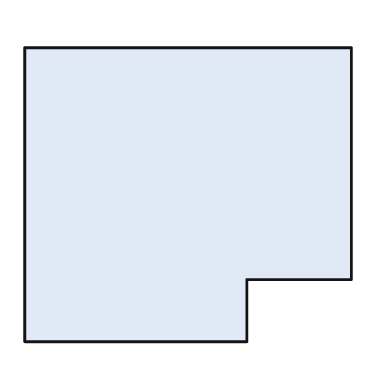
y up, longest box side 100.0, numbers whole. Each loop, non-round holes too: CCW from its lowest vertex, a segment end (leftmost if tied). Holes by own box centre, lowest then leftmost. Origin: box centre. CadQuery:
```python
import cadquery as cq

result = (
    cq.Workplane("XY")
    .moveTo(-50.0, -45.0)
    .lineTo(18.0, -45.0)
    .lineTo(18.0, -26.0)
    .lineTo(50.0, -26.0)
    .lineTo(50.0, 45.0)
    .lineTo(-50.0, 45.0)
    .close()
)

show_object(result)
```